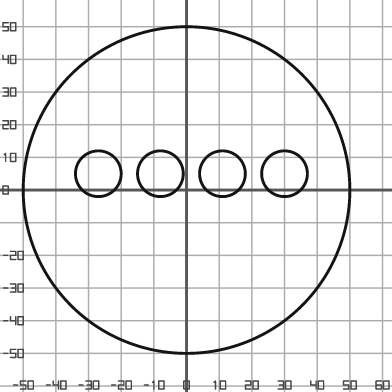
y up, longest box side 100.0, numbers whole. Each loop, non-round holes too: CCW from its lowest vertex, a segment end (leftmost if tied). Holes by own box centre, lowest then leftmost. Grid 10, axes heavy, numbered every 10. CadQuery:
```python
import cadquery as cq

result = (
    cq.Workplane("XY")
    .moveTo(0.0, 0.0)
    .circle(50.0)
    .moveTo(-27.0, 5.0)
    .circle(7.0)
    .moveTo(-8.0, 5.0)
    .circle(7.0)
    .moveTo(11.0, 5.0)
    .circle(7.0)
    .moveTo(30.0, 5.0)
    .circle(7.0)
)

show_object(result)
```